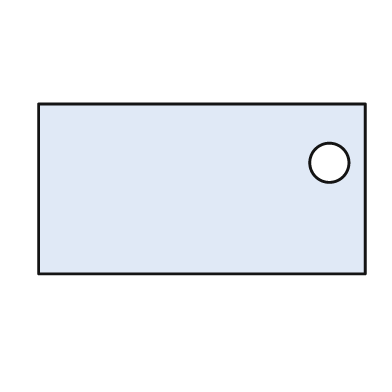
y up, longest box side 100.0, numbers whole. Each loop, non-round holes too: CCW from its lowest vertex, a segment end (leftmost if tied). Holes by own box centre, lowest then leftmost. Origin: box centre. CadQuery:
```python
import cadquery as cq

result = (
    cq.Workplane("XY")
    .moveTo(-50.0, -26.0)
    .lineTo(50.0, -26.0)
    .lineTo(50.0, 26.0)
    .lineTo(-50.0, 26.0)
    .close()
    .moveTo(39.0, 8.0)
    .circle(6.0)
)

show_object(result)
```